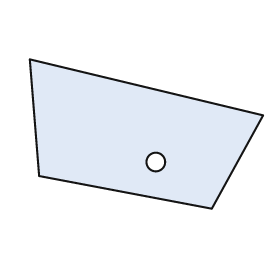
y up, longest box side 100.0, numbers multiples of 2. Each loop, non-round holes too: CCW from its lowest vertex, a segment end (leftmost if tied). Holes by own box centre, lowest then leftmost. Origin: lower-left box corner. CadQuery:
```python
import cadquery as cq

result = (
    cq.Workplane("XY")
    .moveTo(78.0, 0.0)
    .lineTo(100.0, 40.0)
    .lineTo(0.0, 64.0)
    .lineTo(4.0, 14.0)
    .close()
    .moveTo(54.0, 20.0)
    .circle(4.0)
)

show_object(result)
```